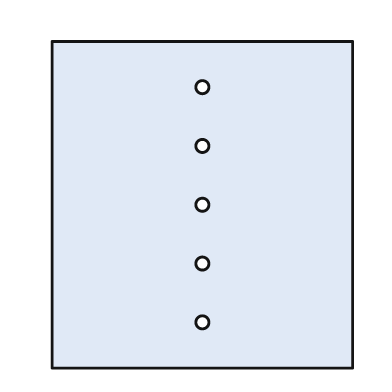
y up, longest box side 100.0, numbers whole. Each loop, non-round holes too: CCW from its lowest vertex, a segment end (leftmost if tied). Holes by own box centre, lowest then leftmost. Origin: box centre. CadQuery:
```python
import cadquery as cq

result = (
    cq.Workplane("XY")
    .moveTo(-46.0, -50.0)
    .lineTo(46.0, -50.0)
    .lineTo(46.0, 50.0)
    .lineTo(-46.0, 50.0)
    .close()
    .moveTo(0.0, -36.0)
    .circle(2.0)
    .moveTo(0.0, -18.0)
    .circle(2.0)
    .moveTo(0.0, 0.0)
    .circle(2.0)
    .moveTo(0.0, 18.0)
    .circle(2.0)
    .moveTo(0.0, 36.0)
    .circle(2.0)
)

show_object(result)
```